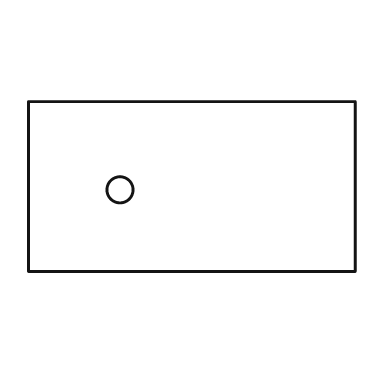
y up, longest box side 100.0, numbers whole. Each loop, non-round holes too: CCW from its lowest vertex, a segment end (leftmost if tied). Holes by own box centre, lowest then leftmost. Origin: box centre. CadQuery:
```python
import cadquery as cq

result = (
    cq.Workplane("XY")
    .moveTo(-50.0, -26.0)
    .lineTo(50.0, -26.0)
    .lineTo(50.0, 26.0)
    .lineTo(-50.0, 26.0)
    .close()
    .moveTo(-22.0, -1.0)
    .circle(4.0)
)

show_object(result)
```